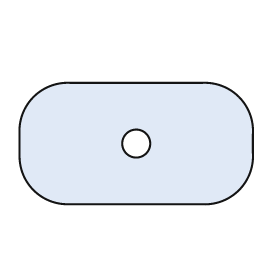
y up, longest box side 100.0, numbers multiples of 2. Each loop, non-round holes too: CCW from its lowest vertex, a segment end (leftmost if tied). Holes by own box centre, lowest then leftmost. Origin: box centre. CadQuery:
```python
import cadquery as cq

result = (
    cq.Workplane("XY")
    .moveTo(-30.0, -26.0)
    .lineTo(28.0, -26.0)
    .threePointArc((44.0, -20.0), (50.0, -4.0))
    .lineTo(50.0, 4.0)
    .threePointArc((44.0, 20.0), (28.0, 26.0))
    .lineTo(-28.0, 26.0)
    .threePointArc((-44.0, 20.0), (-50.0, 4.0))
    .lineTo(-50.0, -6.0)
    .threePointArc((-44.0, -20.0), (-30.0, -26.0))
    .close()
    .moveTo(0.0, 0.0)
    .circle(6.0)
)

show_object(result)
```